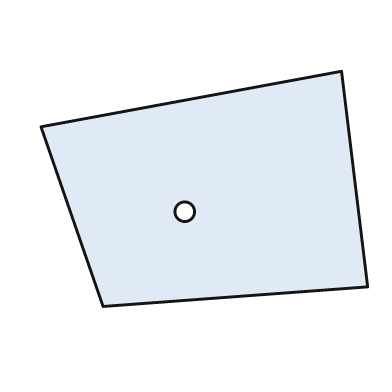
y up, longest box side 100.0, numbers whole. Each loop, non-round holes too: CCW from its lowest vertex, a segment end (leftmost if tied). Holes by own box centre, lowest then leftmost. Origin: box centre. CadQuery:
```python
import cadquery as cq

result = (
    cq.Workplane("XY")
    .moveTo(-31.0, -36.0)
    .lineTo(50.0, -30.0)
    .lineTo(42.0, 36.0)
    .lineTo(-50.0, 19.0)
    .close()
    .moveTo(-6.0, -7.0)
    .circle(3.0)
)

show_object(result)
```